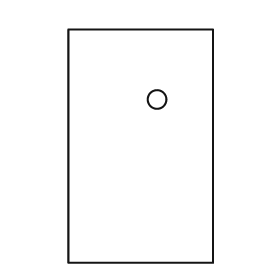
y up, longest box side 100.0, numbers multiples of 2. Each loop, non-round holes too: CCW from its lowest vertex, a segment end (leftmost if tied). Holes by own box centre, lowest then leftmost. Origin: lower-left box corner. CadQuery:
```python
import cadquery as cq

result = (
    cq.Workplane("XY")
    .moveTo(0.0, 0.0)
    .lineTo(62.0, 0.0)
    .lineTo(62.0, 100.0)
    .lineTo(0.0, 100.0)
    .close()
    .moveTo(38.0, 70.0)
    .circle(4.0)
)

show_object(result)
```